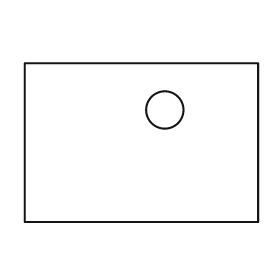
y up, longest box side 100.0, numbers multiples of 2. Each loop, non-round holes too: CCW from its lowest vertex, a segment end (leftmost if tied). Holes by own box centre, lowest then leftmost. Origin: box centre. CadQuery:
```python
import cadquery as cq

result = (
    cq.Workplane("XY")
    .moveTo(-50.0, -34.0)
    .lineTo(50.0, -34.0)
    .lineTo(50.0, 34.0)
    .lineTo(-50.0, 34.0)
    .close()
    .moveTo(10.0, 14.0)
    .circle(8.0)
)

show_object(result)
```